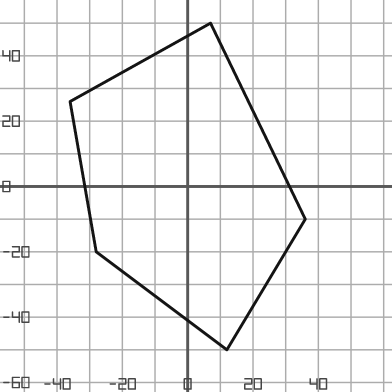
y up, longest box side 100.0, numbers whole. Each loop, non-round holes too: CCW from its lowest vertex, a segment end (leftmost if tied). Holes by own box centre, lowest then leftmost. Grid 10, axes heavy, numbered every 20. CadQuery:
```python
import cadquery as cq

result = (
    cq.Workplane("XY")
    .moveTo(12.0, -50.0)
    .lineTo(36.0, -10.0)
    .lineTo(7.0, 50.0)
    .lineTo(-36.0, 26.0)
    .lineTo(-28.0, -20.0)
    .close()
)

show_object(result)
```